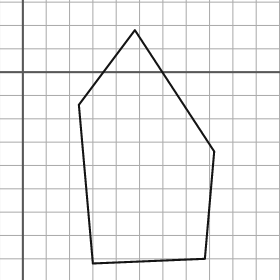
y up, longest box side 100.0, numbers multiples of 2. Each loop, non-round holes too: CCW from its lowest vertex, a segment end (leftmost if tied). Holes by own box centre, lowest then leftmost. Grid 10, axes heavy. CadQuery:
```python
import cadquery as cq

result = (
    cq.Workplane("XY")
    .moveTo(30.0, -82.0)
    .lineTo(78.0, -80.0)
    .lineTo(82.0, -34.0)
    .lineTo(48.0, 18.0)
    .lineTo(24.0, -14.0)
    .close()
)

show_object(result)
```